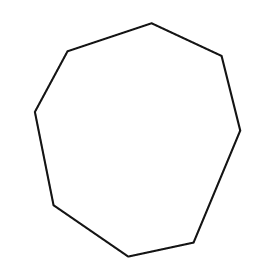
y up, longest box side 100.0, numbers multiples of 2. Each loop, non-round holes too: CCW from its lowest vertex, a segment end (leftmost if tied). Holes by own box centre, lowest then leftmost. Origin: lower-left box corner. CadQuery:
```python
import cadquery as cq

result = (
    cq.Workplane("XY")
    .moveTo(40.0, 0.0)
    .lineTo(68.0, 6.0)
    .lineTo(88.0, 54.0)
    .lineTo(80.0, 86.0)
    .lineTo(50.0, 100.0)
    .lineTo(14.0, 88.0)
    .lineTo(0.0, 62.0)
    .lineTo(8.0, 22.0)
    .close()
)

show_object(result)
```